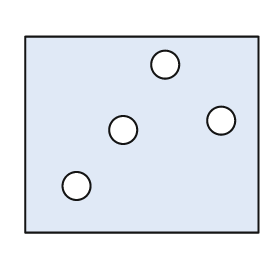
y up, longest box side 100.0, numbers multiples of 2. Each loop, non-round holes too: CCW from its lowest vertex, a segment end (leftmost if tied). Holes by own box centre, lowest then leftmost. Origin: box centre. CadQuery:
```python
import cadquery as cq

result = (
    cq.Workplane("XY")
    .moveTo(-50.0, -42.0)
    .lineTo(50.0, -42.0)
    .lineTo(50.0, 42.0)
    .lineTo(-50.0, 42.0)
    .close()
    .moveTo(-28.0, -22.0)
    .circle(6.0)
    .moveTo(-8.0, 2.0)
    .circle(6.0)
    .moveTo(34.0, 6.0)
    .circle(6.0)
    .moveTo(10.0, 30.0)
    .circle(6.0)
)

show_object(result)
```